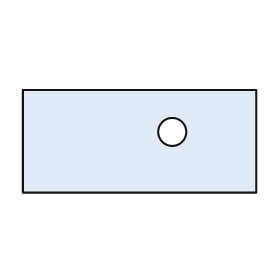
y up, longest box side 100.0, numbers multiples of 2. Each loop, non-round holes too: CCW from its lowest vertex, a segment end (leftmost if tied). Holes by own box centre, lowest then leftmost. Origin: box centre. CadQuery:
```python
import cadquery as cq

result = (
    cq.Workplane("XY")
    .moveTo(-50.0, -22.0)
    .lineTo(50.0, -22.0)
    .lineTo(50.0, 22.0)
    .lineTo(-50.0, 22.0)
    .close()
    .moveTo(14.0, 4.0)
    .circle(6.0)
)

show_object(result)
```